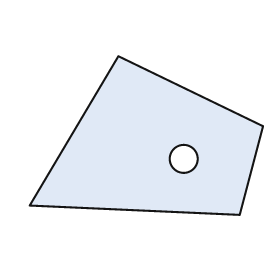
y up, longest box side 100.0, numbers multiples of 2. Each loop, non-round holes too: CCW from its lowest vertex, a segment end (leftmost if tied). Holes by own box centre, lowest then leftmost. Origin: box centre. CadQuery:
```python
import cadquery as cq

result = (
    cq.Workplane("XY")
    .moveTo(40.0, -34.0)
    .lineTo(50.0, 4.0)
    .lineTo(-12.0, 34.0)
    .lineTo(-50.0, -30.0)
    .close()
    .moveTo(16.0, -10.0)
    .circle(6.0)
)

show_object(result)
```